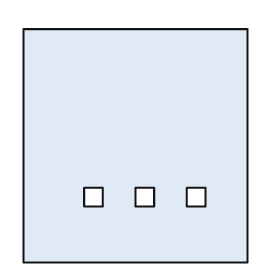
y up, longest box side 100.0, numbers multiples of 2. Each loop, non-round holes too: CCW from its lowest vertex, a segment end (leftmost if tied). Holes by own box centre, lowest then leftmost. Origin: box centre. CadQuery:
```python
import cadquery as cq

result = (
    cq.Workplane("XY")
    .moveTo(-48.0, -50.0)
    .lineTo(48.0, -50.0)
    .lineTo(48.0, 50.0)
    .lineTo(-48.0, 50.0)
    .close()
    .moveTo(-22.0, -26.0)
    .lineTo(-14.0, -26.0)
    .lineTo(-14.0, -18.0)
    .lineTo(-22.0, -18.0)
    .close()
    .moveTo(0.0, -26.0)
    .lineTo(8.0, -26.0)
    .lineTo(8.0, -18.0)
    .lineTo(0.0, -18.0)
    .close()
    .moveTo(22.0, -26.0)
    .lineTo(30.0, -26.0)
    .lineTo(30.0, -18.0)
    .lineTo(22.0, -18.0)
    .close()
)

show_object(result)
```